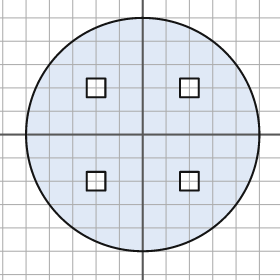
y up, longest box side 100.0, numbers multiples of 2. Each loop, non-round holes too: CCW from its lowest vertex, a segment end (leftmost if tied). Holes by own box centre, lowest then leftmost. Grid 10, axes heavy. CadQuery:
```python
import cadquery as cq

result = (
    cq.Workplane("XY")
    .moveTo(0.0, 0.0)
    .circle(50.0)
    .moveTo(-24.0, -24.0)
    .lineTo(-16.0, -24.0)
    .lineTo(-16.0, -16.0)
    .lineTo(-24.0, -16.0)
    .close()
    .moveTo(16.0, -24.0)
    .lineTo(24.0, -24.0)
    .lineTo(24.0, -16.0)
    .lineTo(16.0, -16.0)
    .close()
    .moveTo(-24.0, 16.0)
    .lineTo(-16.0, 16.0)
    .lineTo(-16.0, 24.0)
    .lineTo(-24.0, 24.0)
    .close()
    .moveTo(16.0, 16.0)
    .lineTo(24.0, 16.0)
    .lineTo(24.0, 24.0)
    .lineTo(16.0, 24.0)
    .close()
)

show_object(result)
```